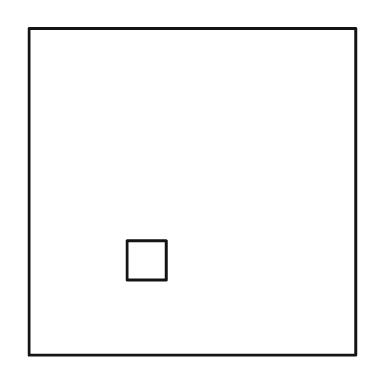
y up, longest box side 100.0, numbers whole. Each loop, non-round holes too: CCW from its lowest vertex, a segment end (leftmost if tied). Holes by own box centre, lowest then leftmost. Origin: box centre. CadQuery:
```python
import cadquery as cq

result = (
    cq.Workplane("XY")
    .moveTo(-50.0, -50.0)
    .lineTo(50.0, -50.0)
    .lineTo(50.0, 50.0)
    .lineTo(-50.0, 50.0)
    .close()
    .moveTo(-20.0, -27.0)
    .lineTo(-8.0, -27.0)
    .lineTo(-8.0, -15.0)
    .lineTo(-20.0, -15.0)
    .close()
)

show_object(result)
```